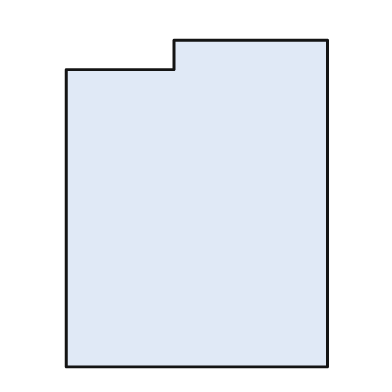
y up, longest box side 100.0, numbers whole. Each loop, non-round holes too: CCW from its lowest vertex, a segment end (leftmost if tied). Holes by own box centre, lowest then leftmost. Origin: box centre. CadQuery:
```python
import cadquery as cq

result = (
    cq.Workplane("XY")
    .moveTo(-40.0, -50.0)
    .lineTo(40.0, -50.0)
    .lineTo(40.0, 50.0)
    .lineTo(-7.0, 50.0)
    .lineTo(-7.0, 41.0)
    .lineTo(-40.0, 41.0)
    .close()
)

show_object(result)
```